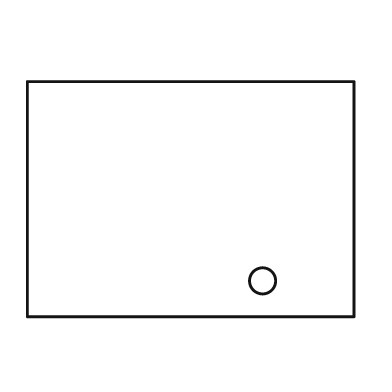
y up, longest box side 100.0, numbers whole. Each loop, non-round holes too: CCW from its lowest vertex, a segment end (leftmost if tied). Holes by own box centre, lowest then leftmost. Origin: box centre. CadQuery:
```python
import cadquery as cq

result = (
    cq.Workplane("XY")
    .moveTo(-50.0, -36.0)
    .lineTo(50.0, -36.0)
    .lineTo(50.0, 36.0)
    .lineTo(-50.0, 36.0)
    .close()
    .moveTo(22.0, -25.0)
    .circle(4.0)
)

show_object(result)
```